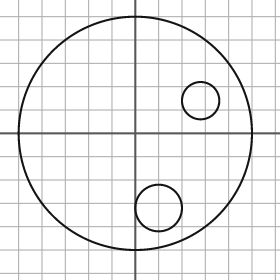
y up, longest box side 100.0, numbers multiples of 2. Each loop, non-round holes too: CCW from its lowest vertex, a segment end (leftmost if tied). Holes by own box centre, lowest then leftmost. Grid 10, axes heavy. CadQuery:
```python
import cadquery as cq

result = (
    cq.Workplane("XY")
    .moveTo(0.0, 0.0)
    .circle(50.0)
    .moveTo(10.0, -32.0)
    .circle(10.0)
    .moveTo(28.0, 14.0)
    .circle(8.0)
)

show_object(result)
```